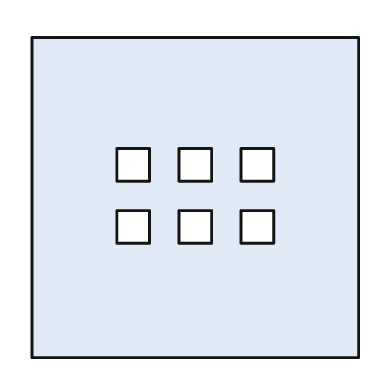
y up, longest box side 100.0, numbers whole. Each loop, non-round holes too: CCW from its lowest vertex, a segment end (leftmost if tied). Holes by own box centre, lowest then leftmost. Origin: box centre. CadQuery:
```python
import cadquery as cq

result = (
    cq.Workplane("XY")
    .moveTo(-50.0, -49.0)
    .lineTo(50.0, -49.0)
    .lineTo(50.0, 49.0)
    .lineTo(-50.0, 49.0)
    .close()
    .moveTo(-24.0, -14.0)
    .lineTo(-14.0, -14.0)
    .lineTo(-14.0, -4.0)
    .lineTo(-24.0, -4.0)
    .close()
    .moveTo(-5.0, -14.0)
    .lineTo(5.0, -14.0)
    .lineTo(5.0, -4.0)
    .lineTo(-5.0, -4.0)
    .close()
    .moveTo(14.0, -14.0)
    .lineTo(24.0, -14.0)
    .lineTo(24.0, -4.0)
    .lineTo(14.0, -4.0)
    .close()
    .moveTo(-24.0, 5.0)
    .lineTo(-14.0, 5.0)
    .lineTo(-14.0, 15.0)
    .lineTo(-24.0, 15.0)
    .close()
    .moveTo(-5.0, 5.0)
    .lineTo(5.0, 5.0)
    .lineTo(5.0, 15.0)
    .lineTo(-5.0, 15.0)
    .close()
    .moveTo(14.0, 5.0)
    .lineTo(24.0, 5.0)
    .lineTo(24.0, 15.0)
    .lineTo(14.0, 15.0)
    .close()
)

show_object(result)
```